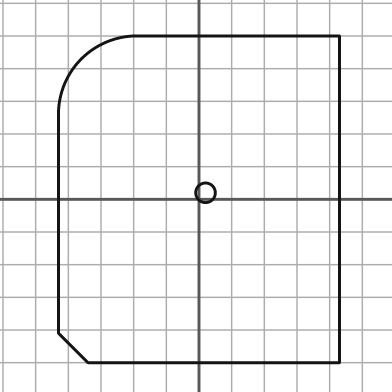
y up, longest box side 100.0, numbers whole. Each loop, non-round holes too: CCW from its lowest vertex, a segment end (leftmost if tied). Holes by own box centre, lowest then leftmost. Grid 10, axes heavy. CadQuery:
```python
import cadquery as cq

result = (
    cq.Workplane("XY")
    .moveTo(-34.0, -50.0)
    .lineTo(43.0, -50.0)
    .lineTo(43.0, 50.0)
    .lineTo(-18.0, 50.0)
    .threePointArc((-36.0, 43.0), (-43.0, 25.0))
    .lineTo(-43.0, -41.0)
    .close()
    .moveTo(2.0, 2.0)
    .circle(3.0)
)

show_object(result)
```